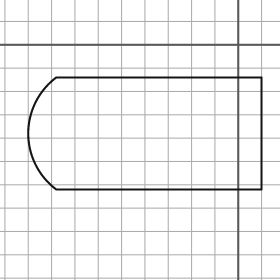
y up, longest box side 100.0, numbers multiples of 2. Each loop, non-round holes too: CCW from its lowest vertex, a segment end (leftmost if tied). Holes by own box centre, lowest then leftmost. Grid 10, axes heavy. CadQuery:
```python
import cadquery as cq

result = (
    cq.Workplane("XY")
    .moveTo(-78.0, -62.0)
    .lineTo(10.0, -62.0)
    .lineTo(10.0, -14.0)
    .lineTo(-78.0, -14.0)
    .threePointArc((-90.0, -38.0), (-78.0, -62.0))
    .close()
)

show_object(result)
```